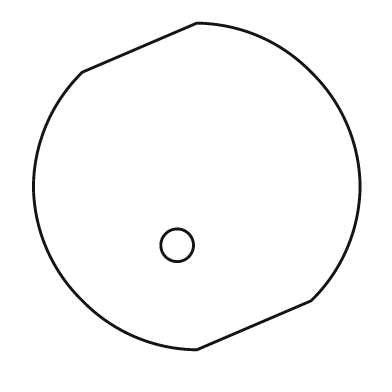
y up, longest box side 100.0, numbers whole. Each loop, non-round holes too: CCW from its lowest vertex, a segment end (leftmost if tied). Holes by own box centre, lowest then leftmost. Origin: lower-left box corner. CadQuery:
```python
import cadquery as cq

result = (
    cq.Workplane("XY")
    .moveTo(50.0, 0.0)
    .lineTo(85.0, 15.0)
    .threePointArc((96.0, 31.0), (100.0, 50.0))
    .threePointArc((96.0, 69.0), (85.0, 85.0))
    .threePointArc((69.0, 96.0), (50.0, 100.0))
    .lineTo(15.0, 85.0)
    .threePointArc((4.0, 69.0), (0.0, 50.0))
    .threePointArc((4.0, 31.0), (15.0, 15.0))
    .threePointArc((31.0, 4.0), (50.0, 0.0))
    .close()
    .moveTo(44.0, 32.0)
    .circle(5.0)
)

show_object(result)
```